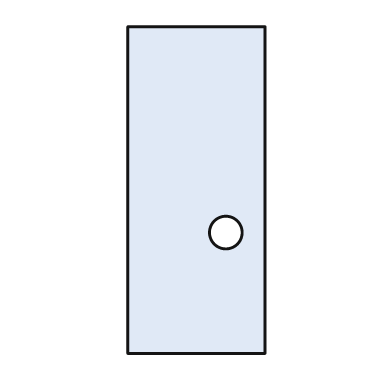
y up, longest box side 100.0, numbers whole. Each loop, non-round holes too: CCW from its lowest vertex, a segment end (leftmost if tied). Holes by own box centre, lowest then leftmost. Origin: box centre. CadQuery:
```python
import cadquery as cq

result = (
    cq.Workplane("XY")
    .moveTo(-21.0, -50.0)
    .lineTo(21.0, -50.0)
    .lineTo(21.0, 50.0)
    .lineTo(-21.0, 50.0)
    .close()
    .moveTo(9.0, -13.0)
    .circle(5.0)
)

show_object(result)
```